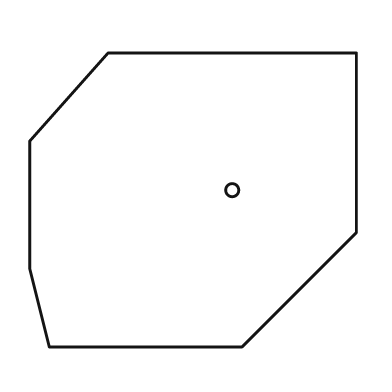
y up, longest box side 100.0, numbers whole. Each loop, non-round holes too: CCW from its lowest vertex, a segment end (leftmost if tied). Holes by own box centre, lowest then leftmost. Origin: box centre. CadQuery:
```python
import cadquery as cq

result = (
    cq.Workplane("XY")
    .moveTo(-44.0, -45.0)
    .lineTo(15.0, -45.0)
    .lineTo(50.0, -10.0)
    .lineTo(50.0, 45.0)
    .lineTo(-26.0, 45.0)
    .lineTo(-50.0, 18.0)
    .lineTo(-50.0, -21.0)
    .close()
    .moveTo(12.0, 3.0)
    .circle(2.0)
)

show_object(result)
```